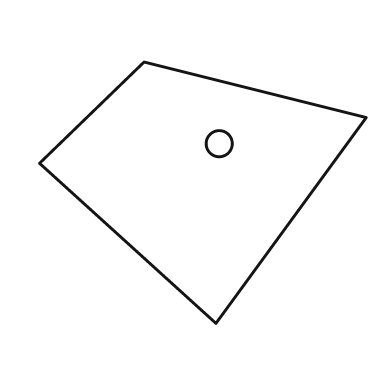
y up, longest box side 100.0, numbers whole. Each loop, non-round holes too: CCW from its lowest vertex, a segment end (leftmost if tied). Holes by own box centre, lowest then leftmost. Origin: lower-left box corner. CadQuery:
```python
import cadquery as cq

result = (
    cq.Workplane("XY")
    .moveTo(54.0, 0.0)
    .lineTo(100.0, 63.0)
    .lineTo(32.0, 80.0)
    .lineTo(0.0, 49.0)
    .close()
    .moveTo(55.0, 55.0)
    .circle(4.0)
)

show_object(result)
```